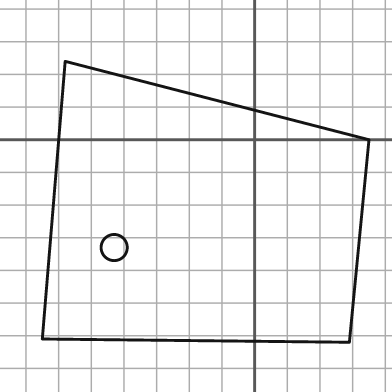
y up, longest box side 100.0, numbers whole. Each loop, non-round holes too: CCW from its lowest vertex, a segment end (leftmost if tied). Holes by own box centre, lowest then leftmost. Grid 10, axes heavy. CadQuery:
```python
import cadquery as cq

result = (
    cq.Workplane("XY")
    .moveTo(29.0, -62.0)
    .lineTo(35.0, 0.0)
    .lineTo(-58.0, 24.0)
    .lineTo(-65.0, -61.0)
    .close()
    .moveTo(-43.0, -33.0)
    .circle(4.0)
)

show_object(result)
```